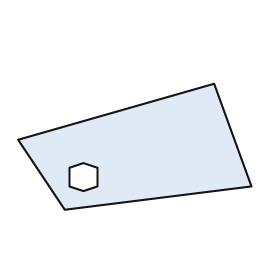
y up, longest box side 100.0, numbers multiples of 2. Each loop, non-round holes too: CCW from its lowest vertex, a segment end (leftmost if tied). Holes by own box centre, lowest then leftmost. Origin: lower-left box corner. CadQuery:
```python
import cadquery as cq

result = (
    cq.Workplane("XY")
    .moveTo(20.0, 0.0)
    .lineTo(100.0, 10.0)
    .lineTo(84.0, 54.0)
    .lineTo(0.0, 30.0)
    .close()
    .moveTo(28.0, 8.0)
    .lineTo(34.0, 10.0)
    .lineTo(34.0, 18.0)
    .lineTo(28.0, 20.0)
    .lineTo(22.0, 18.0)
    .lineTo(22.0, 10.0)
    .close()
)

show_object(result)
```